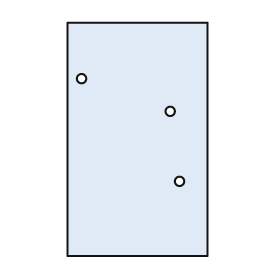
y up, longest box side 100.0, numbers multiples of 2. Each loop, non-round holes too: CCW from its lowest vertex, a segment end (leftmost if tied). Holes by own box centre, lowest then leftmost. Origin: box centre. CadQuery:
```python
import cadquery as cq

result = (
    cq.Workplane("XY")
    .moveTo(-30.0, -50.0)
    .lineTo(30.0, -50.0)
    .lineTo(30.0, 50.0)
    .lineTo(-30.0, 50.0)
    .close()
    .moveTo(18.0, -18.0)
    .circle(2.0)
    .moveTo(14.0, 12.0)
    .circle(2.0)
    .moveTo(-24.0, 26.0)
    .circle(2.0)
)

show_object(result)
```